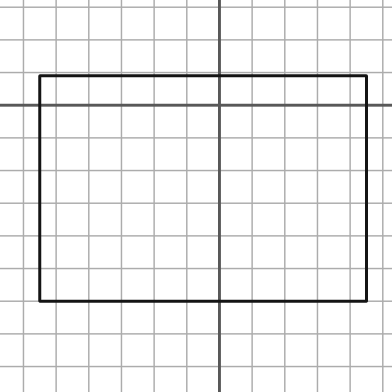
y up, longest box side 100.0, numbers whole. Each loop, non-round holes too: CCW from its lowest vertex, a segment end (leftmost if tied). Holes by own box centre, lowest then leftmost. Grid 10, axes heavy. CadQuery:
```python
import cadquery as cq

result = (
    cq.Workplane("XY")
    .moveTo(-55.0, -60.0)
    .lineTo(45.0, -60.0)
    .lineTo(45.0, 9.0)
    .lineTo(-55.0, 9.0)
    .close()
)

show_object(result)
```